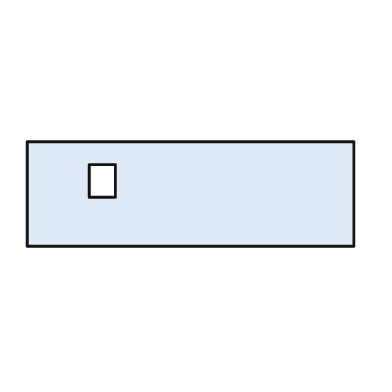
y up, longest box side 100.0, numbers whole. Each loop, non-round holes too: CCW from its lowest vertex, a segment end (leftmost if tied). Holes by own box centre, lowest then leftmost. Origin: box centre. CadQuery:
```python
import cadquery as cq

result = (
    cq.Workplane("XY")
    .moveTo(-50.0, -16.0)
    .lineTo(50.0, -16.0)
    .lineTo(50.0, 16.0)
    .lineTo(-50.0, 16.0)
    .close()
    .moveTo(-31.0, -1.0)
    .lineTo(-23.0, -1.0)
    .lineTo(-23.0, 9.0)
    .lineTo(-31.0, 9.0)
    .close()
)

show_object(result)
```